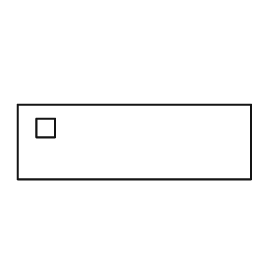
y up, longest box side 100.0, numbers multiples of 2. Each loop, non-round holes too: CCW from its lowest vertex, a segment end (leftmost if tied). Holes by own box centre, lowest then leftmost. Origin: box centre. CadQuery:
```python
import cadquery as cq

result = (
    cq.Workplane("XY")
    .moveTo(-50.0, -16.0)
    .lineTo(50.0, -16.0)
    .lineTo(50.0, 16.0)
    .lineTo(-50.0, 16.0)
    .close()
    .moveTo(-42.0, 2.0)
    .lineTo(-34.0, 2.0)
    .lineTo(-34.0, 10.0)
    .lineTo(-42.0, 10.0)
    .close()
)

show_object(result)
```